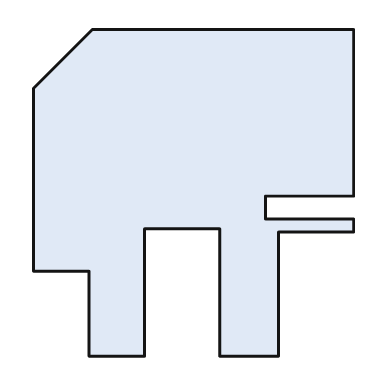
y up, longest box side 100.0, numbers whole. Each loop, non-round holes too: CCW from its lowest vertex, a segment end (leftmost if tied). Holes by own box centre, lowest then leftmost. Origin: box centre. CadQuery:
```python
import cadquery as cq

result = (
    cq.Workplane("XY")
    .moveTo(-32.0, -50.0)
    .lineTo(-15.0, -50.0)
    .lineTo(-15.0, -11.0)
    .lineTo(8.0, -11.0)
    .lineTo(8.0, -50.0)
    .lineTo(26.0, -50.0)
    .lineTo(26.0, -12.0)
    .lineTo(49.0, -12.0)
    .lineTo(49.0, -8.0)
    .lineTo(22.0, -8.0)
    .lineTo(22.0, -1.0)
    .lineTo(49.0, -1.0)
    .lineTo(49.0, 50.0)
    .lineTo(-31.0, 50.0)
    .lineTo(-49.0, 32.0)
    .lineTo(-49.0, -24.0)
    .lineTo(-32.0, -24.0)
    .close()
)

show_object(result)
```